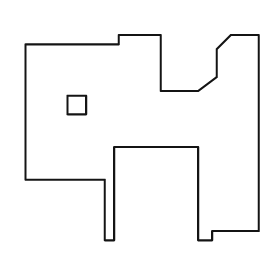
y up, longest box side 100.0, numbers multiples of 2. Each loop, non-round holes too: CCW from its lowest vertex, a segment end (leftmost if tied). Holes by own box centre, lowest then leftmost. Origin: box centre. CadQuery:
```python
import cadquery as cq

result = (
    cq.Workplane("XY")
    .moveTo(-16.0, -44.0)
    .lineTo(-12.0, -44.0)
    .lineTo(-12.0, -4.0)
    .lineTo(24.0, -4.0)
    .lineTo(24.0, -44.0)
    .lineTo(30.0, -44.0)
    .lineTo(30.0, -40.0)
    .lineTo(50.0, -40.0)
    .lineTo(50.0, 44.0)
    .lineTo(38.0, 44.0)
    .lineTo(32.0, 38.0)
    .lineTo(32.0, 26.0)
    .lineTo(24.0, 20.0)
    .lineTo(8.0, 20.0)
    .lineTo(8.0, 44.0)
    .lineTo(-10.0, 44.0)
    .lineTo(-10.0, 40.0)
    .lineTo(-50.0, 40.0)
    .lineTo(-50.0, -18.0)
    .lineTo(-16.0, -18.0)
    .close()
    .moveTo(-32.0, 10.0)
    .lineTo(-24.0, 10.0)
    .lineTo(-24.0, 18.0)
    .lineTo(-32.0, 18.0)
    .close()
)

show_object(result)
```